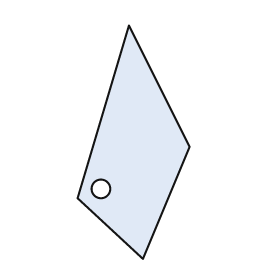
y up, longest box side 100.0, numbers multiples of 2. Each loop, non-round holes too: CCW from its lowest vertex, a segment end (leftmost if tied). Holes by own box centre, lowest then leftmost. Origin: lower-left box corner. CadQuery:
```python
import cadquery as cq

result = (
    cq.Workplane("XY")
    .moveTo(28.0, 0.0)
    .lineTo(48.0, 48.0)
    .lineTo(22.0, 100.0)
    .lineTo(0.0, 26.0)
    .close()
    .moveTo(10.0, 30.0)
    .circle(4.0)
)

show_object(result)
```